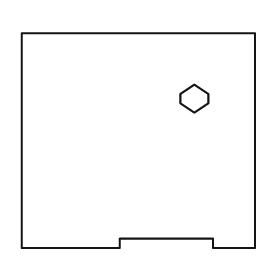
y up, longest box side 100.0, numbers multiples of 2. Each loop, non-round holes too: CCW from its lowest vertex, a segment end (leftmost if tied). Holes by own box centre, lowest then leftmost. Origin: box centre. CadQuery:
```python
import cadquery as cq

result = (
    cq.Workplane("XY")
    .moveTo(-50.0, -46.0)
    .lineTo(-8.0, -46.0)
    .lineTo(-8.0, -42.0)
    .lineTo(32.0, -42.0)
    .lineTo(32.0, -46.0)
    .lineTo(50.0, -46.0)
    .lineTo(50.0, 46.0)
    .lineTo(-50.0, 46.0)
    .close()
    .moveTo(24.0, 12.0)
    .lineTo(30.0, 16.0)
    .lineTo(30.0, 20.0)
    .lineTo(24.0, 24.0)
    .lineTo(18.0, 20.0)
    .lineTo(18.0, 16.0)
    .close()
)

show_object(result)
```